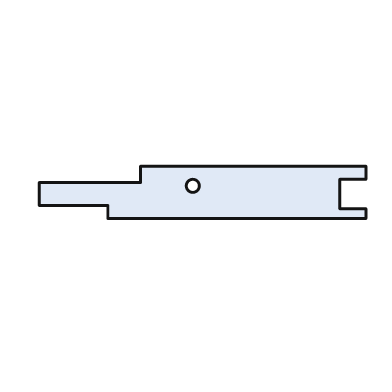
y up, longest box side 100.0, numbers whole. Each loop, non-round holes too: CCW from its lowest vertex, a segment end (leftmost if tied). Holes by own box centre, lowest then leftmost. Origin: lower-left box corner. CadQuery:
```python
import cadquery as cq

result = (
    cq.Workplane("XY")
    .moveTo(21.0, 0.0)
    .lineTo(100.0, 0.0)
    .lineTo(100.0, 3.0)
    .lineTo(92.0, 3.0)
    .lineTo(92.0, 12.0)
    .lineTo(100.0, 12.0)
    .lineTo(100.0, 16.0)
    .lineTo(31.0, 16.0)
    .lineTo(31.0, 11.0)
    .lineTo(0.0, 11.0)
    .lineTo(0.0, 4.0)
    .lineTo(21.0, 4.0)
    .close()
    .moveTo(47.0, 10.0)
    .circle(2.0)
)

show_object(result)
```